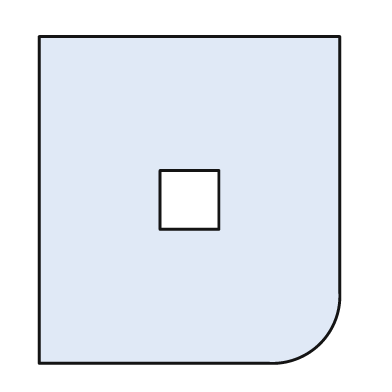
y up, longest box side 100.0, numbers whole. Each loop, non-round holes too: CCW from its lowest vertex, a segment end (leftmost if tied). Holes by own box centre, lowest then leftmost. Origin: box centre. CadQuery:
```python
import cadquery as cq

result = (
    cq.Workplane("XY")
    .moveTo(-46.0, -50.0)
    .lineTo(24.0, -50.0)
    .threePointArc((40.0, -44.0), (46.0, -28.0))
    .lineTo(46.0, 50.0)
    .lineTo(-46.0, 50.0)
    .close()
    .moveTo(-9.0, -9.0)
    .lineTo(9.0, -9.0)
    .lineTo(9.0, 9.0)
    .lineTo(-9.0, 9.0)
    .close()
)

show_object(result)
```